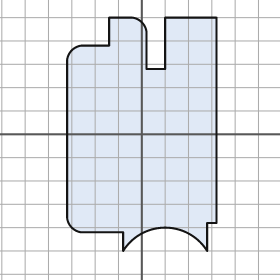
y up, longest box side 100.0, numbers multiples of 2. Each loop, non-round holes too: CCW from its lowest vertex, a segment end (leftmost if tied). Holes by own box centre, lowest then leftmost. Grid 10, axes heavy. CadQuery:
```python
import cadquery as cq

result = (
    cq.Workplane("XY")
    .moveTo(-8.0, -50.0)
    .threePointArc((10.0, -40.0), (28.0, -50.0))
    .lineTo(28.0, -38.0)
    .lineTo(32.0, -38.0)
    .lineTo(32.0, 50.0)
    .lineTo(10.0, 50.0)
    .lineTo(10.0, 28.0)
    .lineTo(2.0, 28.0)
    .lineTo(2.0, 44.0)
    .threePointArc((0.0, 48.0), (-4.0, 50.0))
    .lineTo(-14.0, 50.0)
    .lineTo(-14.0, 38.0)
    .lineTo(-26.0, 38.0)
    .threePointArc((-30.0, 36.0), (-32.0, 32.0))
    .lineTo(-32.0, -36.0)
    .threePointArc((-30.0, -40.0), (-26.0, -42.0))
    .lineTo(-8.0, -42.0)
    .close()
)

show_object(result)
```